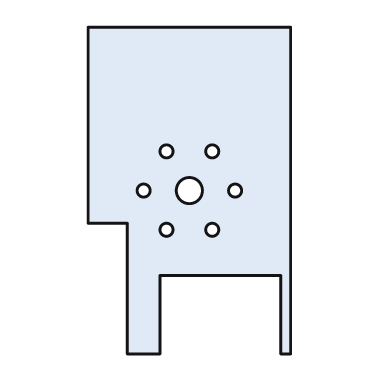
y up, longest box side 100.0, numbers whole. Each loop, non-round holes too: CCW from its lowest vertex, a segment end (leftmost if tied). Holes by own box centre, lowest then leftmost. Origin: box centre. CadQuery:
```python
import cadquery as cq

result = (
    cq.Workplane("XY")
    .moveTo(-19.0, -50.0)
    .lineTo(-9.0, -50.0)
    .lineTo(-9.0, -26.0)
    .lineTo(28.0, -26.0)
    .lineTo(28.0, -50.0)
    .lineTo(31.0, -50.0)
    .lineTo(31.0, 50.0)
    .lineTo(-31.0, 50.0)
    .lineTo(-31.0, -10.0)
    .lineTo(-19.0, -10.0)
    .close()
    .moveTo(-7.0, -12.0)
    .circle(2.0)
    .moveTo(7.0, -12.0)
    .circle(2.0)
    .moveTo(-14.0, 0.0)
    .circle(2.0)
    .moveTo(0.0, 0.0)
    .circle(4.0)
    .moveTo(14.0, 0.0)
    .circle(2.0)
    .moveTo(-7.0, 12.0)
    .circle(2.0)
    .moveTo(7.0, 12.0)
    .circle(2.0)
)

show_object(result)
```